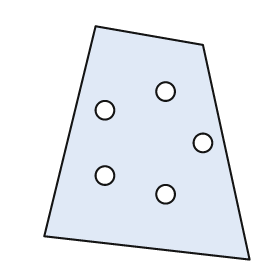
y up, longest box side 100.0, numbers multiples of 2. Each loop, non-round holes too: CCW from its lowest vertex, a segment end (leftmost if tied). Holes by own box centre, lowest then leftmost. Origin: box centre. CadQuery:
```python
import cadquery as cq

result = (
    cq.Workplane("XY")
    .moveTo(44.0, -50.0)
    .lineTo(24.0, 42.0)
    .lineTo(-22.0, 50.0)
    .lineTo(-44.0, -40.0)
    .close()
    .moveTo(8.0, -22.0)
    .circle(4.0)
    .moveTo(-18.0, -14.0)
    .circle(4.0)
    .moveTo(24.0, 0.0)
    .circle(4.0)
    .moveTo(-18.0, 14.0)
    .circle(4.0)
    .moveTo(8.0, 22.0)
    .circle(4.0)
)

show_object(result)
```